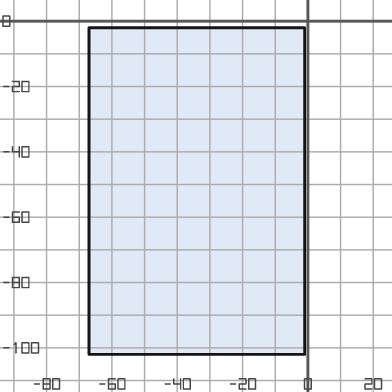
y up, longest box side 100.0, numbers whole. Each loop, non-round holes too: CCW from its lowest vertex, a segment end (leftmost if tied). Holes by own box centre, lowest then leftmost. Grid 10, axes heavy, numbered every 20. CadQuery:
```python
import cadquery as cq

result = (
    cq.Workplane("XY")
    .moveTo(-67.0, -102.0)
    .lineTo(-1.0, -102.0)
    .lineTo(-1.0, -2.0)
    .lineTo(-67.0, -2.0)
    .close()
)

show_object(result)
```